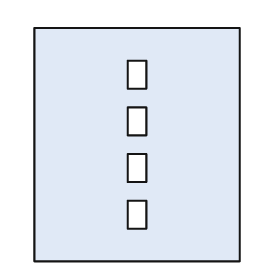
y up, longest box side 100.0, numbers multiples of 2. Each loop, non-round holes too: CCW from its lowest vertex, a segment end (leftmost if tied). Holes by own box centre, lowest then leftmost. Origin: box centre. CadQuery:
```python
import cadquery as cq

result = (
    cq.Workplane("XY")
    .moveTo(-44.0, -50.0)
    .lineTo(44.0, -50.0)
    .lineTo(44.0, 50.0)
    .lineTo(-44.0, 50.0)
    .close()
    .moveTo(-4.0, -36.0)
    .lineTo(4.0, -36.0)
    .lineTo(4.0, -24.0)
    .lineTo(-4.0, -24.0)
    .close()
    .moveTo(-4.0, -16.0)
    .lineTo(4.0, -16.0)
    .lineTo(4.0, -4.0)
    .lineTo(-4.0, -4.0)
    .close()
    .moveTo(-4.0, 4.0)
    .lineTo(4.0, 4.0)
    .lineTo(4.0, 16.0)
    .lineTo(-4.0, 16.0)
    .close()
    .moveTo(-4.0, 24.0)
    .lineTo(4.0, 24.0)
    .lineTo(4.0, 36.0)
    .lineTo(-4.0, 36.0)
    .close()
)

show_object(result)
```